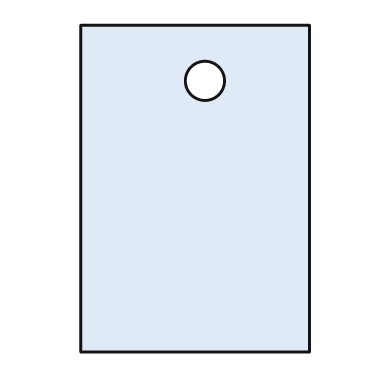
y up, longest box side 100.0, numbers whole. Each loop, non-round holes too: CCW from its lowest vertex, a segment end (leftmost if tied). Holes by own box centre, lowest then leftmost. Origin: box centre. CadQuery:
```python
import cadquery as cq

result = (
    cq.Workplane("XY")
    .moveTo(-35.0, -50.0)
    .lineTo(35.0, -50.0)
    .lineTo(35.0, 50.0)
    .lineTo(-35.0, 50.0)
    .close()
    .moveTo(3.0, 33.0)
    .circle(6.0)
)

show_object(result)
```